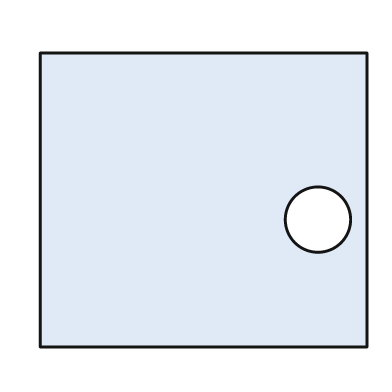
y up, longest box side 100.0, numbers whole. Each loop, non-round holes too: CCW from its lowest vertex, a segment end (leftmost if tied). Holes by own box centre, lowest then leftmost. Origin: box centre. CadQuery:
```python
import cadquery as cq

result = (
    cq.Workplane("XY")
    .moveTo(-50.0, -45.0)
    .lineTo(50.0, -45.0)
    .lineTo(50.0, 45.0)
    .lineTo(-50.0, 45.0)
    .close()
    .moveTo(35.0, -6.0)
    .circle(10.0)
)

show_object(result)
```